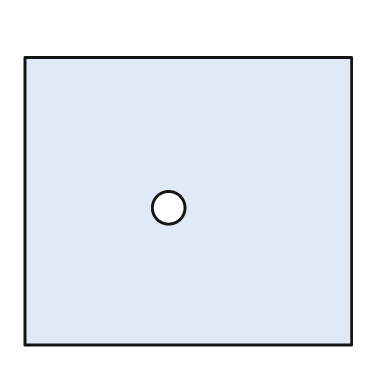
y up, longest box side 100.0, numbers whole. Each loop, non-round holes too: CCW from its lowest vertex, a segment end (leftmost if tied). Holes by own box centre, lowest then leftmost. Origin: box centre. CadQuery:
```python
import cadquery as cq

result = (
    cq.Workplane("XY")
    .moveTo(-50.0, -44.0)
    .lineTo(50.0, -44.0)
    .lineTo(50.0, 44.0)
    .lineTo(-50.0, 44.0)
    .close()
    .moveTo(-6.0, -2.0)
    .circle(5.0)
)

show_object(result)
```